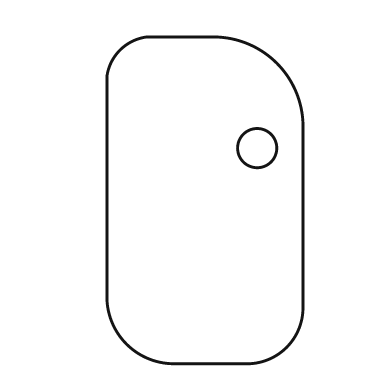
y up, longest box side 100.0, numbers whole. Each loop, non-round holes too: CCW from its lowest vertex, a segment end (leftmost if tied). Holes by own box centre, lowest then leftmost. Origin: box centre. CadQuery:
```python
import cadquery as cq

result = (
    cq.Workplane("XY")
    .moveTo(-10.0, -50.0)
    .lineTo(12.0, -50.0)
    .threePointArc((25.0, -45.0), (30.0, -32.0))
    .lineTo(30.0, 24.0)
    .threePointArc((22.0, 42.0), (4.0, 50.0))
    .lineTo(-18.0, 50.0)
    .threePointArc((-26.0, 46.0), (-30.0, 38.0))
    .lineTo(-30.0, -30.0)
    .threePointArc((-24.0, -44.0), (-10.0, -50.0))
    .close()
    .moveTo(16.0, 16.0)
    .circle(6.0)
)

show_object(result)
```